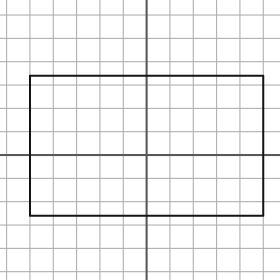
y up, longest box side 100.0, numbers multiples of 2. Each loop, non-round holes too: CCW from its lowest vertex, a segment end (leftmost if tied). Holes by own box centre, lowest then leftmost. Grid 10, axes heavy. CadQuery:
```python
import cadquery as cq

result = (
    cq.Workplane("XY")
    .moveTo(-50.0, -26.0)
    .lineTo(50.0, -26.0)
    .lineTo(50.0, 34.0)
    .lineTo(-50.0, 34.0)
    .close()
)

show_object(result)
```